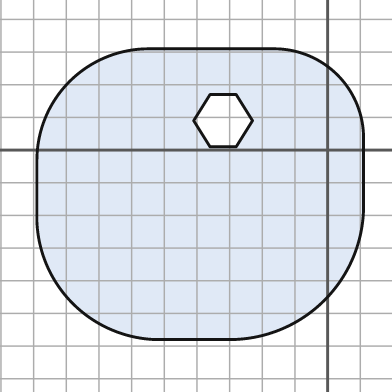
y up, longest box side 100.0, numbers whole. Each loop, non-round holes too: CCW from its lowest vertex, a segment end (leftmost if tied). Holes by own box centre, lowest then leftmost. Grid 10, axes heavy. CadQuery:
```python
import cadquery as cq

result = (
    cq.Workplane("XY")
    .moveTo(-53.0, -58.0)
    .lineTo(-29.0, -58.0)
    .threePointArc((-1.0, -46.0), (11.0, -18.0))
    .lineTo(11.0, 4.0)
    .threePointArc((3.0, 23.0), (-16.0, 31.0))
    .lineTo(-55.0, 31.0)
    .threePointArc((-79.0, 21.0), (-89.0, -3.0))
    .lineTo(-89.0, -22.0)
    .threePointArc((-78.0, -47.0), (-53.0, -58.0))
    .close()
    .moveTo(-36.0, 1.0)
    .lineTo(-28.0, 1.0)
    .lineTo(-23.0, 9.0)
    .lineTo(-28.0, 17.0)
    .lineTo(-36.0, 17.0)
    .lineTo(-41.0, 9.0)
    .close()
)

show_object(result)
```